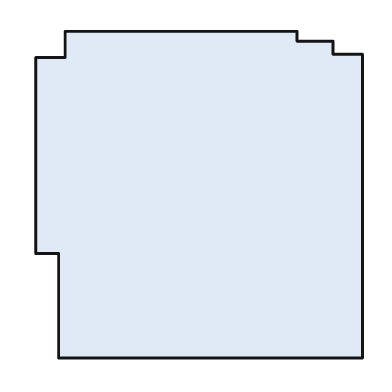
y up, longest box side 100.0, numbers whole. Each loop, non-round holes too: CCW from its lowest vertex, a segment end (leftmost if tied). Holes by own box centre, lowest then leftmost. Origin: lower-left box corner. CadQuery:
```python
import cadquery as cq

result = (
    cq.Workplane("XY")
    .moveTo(7.0, 0.0)
    .lineTo(100.0, 0.0)
    .lineTo(100.0, 93.0)
    .lineTo(91.0, 93.0)
    .lineTo(91.0, 97.0)
    .lineTo(80.0, 97.0)
    .lineTo(80.0, 100.0)
    .lineTo(9.0, 100.0)
    .lineTo(9.0, 92.0)
    .lineTo(0.0, 92.0)
    .lineTo(0.0, 32.0)
    .lineTo(7.0, 32.0)
    .close()
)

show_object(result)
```